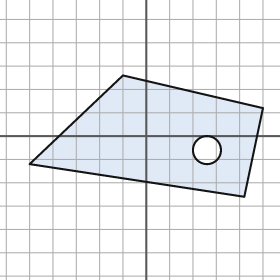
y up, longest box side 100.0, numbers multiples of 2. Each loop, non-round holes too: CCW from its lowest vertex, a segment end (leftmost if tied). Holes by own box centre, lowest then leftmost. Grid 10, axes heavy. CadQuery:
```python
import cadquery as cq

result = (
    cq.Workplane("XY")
    .moveTo(42.0, -26.0)
    .lineTo(50.0, 12.0)
    .lineTo(-10.0, 26.0)
    .lineTo(-50.0, -12.0)
    .close()
    .moveTo(26.0, -6.0)
    .circle(6.0)
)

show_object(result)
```